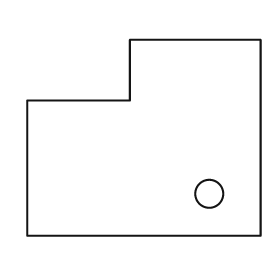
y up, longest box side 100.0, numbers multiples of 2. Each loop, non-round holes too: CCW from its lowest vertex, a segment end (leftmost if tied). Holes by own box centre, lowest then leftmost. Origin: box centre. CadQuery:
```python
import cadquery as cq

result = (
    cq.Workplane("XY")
    .moveTo(-50.0, -42.0)
    .lineTo(50.0, -42.0)
    .lineTo(50.0, 42.0)
    .lineTo(-6.0, 42.0)
    .lineTo(-6.0, 16.0)
    .lineTo(-50.0, 16.0)
    .close()
    .moveTo(28.0, -24.0)
    .circle(6.0)
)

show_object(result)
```